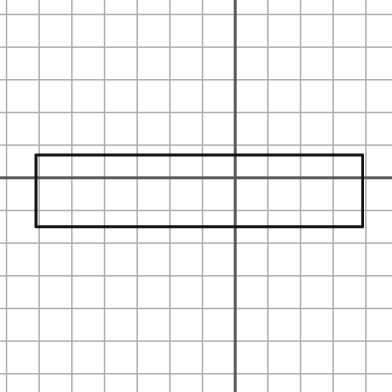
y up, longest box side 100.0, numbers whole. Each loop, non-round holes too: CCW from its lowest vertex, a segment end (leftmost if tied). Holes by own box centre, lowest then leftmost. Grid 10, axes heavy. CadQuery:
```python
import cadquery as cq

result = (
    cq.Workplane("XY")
    .moveTo(-61.0, -15.0)
    .lineTo(39.0, -15.0)
    .lineTo(39.0, 7.0)
    .lineTo(-61.0, 7.0)
    .close()
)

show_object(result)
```